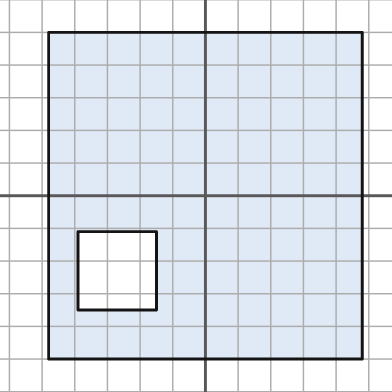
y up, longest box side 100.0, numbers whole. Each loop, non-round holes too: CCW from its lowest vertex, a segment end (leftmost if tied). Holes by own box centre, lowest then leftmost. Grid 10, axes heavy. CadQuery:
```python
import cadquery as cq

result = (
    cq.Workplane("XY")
    .moveTo(-48.0, -50.0)
    .lineTo(48.0, -50.0)
    .lineTo(48.0, 50.0)
    .lineTo(-48.0, 50.0)
    .close()
    .moveTo(-39.0, -35.0)
    .lineTo(-15.0, -35.0)
    .lineTo(-15.0, -11.0)
    .lineTo(-39.0, -11.0)
    .close()
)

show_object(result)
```